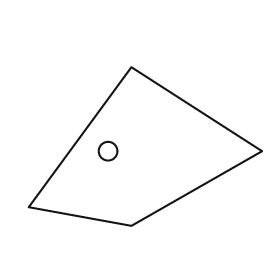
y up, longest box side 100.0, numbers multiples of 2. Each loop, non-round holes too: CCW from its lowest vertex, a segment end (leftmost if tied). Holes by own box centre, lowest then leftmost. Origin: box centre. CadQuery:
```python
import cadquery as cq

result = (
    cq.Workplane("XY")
    .moveTo(-6.0, -34.0)
    .lineTo(50.0, -2.0)
    .lineTo(-6.0, 34.0)
    .lineTo(-50.0, -26.0)
    .close()
    .moveTo(-16.0, -2.0)
    .circle(4.0)
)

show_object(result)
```